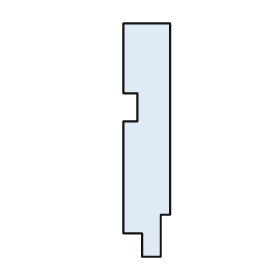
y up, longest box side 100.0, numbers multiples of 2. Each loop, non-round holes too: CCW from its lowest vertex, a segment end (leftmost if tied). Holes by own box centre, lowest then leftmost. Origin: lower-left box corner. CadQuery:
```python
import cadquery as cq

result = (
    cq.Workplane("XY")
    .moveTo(8.0, 0.0)
    .lineTo(16.0, 0.0)
    .lineTo(16.0, 18.0)
    .lineTo(20.0, 18.0)
    .lineTo(20.0, 100.0)
    .lineTo(0.0, 100.0)
    .lineTo(0.0, 70.0)
    .lineTo(6.0, 70.0)
    .lineTo(6.0, 58.0)
    .lineTo(0.0, 58.0)
    .lineTo(0.0, 10.0)
    .lineTo(8.0, 10.0)
    .close()
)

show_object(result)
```